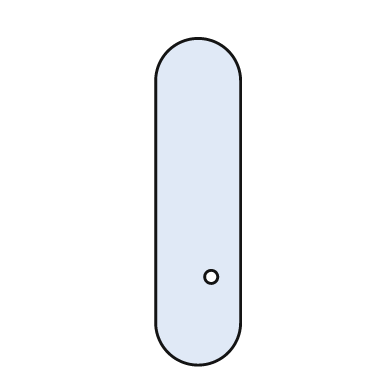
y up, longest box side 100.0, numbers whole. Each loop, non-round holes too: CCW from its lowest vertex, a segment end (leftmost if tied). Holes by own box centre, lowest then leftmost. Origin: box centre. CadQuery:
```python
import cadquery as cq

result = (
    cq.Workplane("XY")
    .moveTo(-13.0, -37.0)
    .threePointArc((0.0, -50.0), (13.0, -37.0))
    .lineTo(13.0, 37.0)
    .threePointArc((0.0, 50.0), (-13.0, 37.0))
    .close()
    .moveTo(4.0, -23.0)
    .circle(2.0)
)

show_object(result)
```